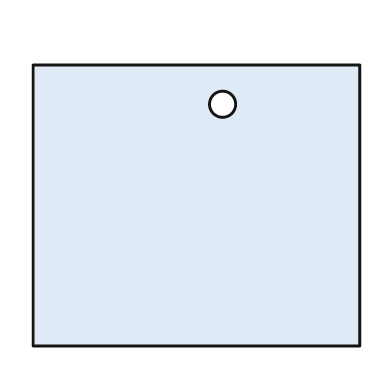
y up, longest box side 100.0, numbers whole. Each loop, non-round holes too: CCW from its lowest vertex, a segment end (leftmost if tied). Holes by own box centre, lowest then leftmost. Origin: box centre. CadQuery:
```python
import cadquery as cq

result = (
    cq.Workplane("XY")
    .moveTo(-50.0, -43.0)
    .lineTo(50.0, -43.0)
    .lineTo(50.0, 43.0)
    .lineTo(-50.0, 43.0)
    .close()
    .moveTo(8.0, 31.0)
    .circle(4.0)
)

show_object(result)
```